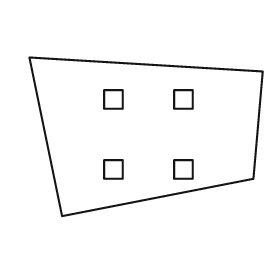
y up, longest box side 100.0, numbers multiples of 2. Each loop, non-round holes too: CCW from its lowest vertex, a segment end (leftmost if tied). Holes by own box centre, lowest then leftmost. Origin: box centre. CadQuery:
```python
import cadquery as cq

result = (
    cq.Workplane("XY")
    .moveTo(-36.0, -34.0)
    .lineTo(46.0, -18.0)
    .lineTo(50.0, 28.0)
    .lineTo(-50.0, 34.0)
    .close()
    .moveTo(-18.0, -18.0)
    .lineTo(-10.0, -18.0)
    .lineTo(-10.0, -10.0)
    .lineTo(-18.0, -10.0)
    .close()
    .moveTo(12.0, -18.0)
    .lineTo(20.0, -18.0)
    .lineTo(20.0, -10.0)
    .lineTo(12.0, -10.0)
    .close()
    .moveTo(-18.0, 12.0)
    .lineTo(-10.0, 12.0)
    .lineTo(-10.0, 20.0)
    .lineTo(-18.0, 20.0)
    .close()
    .moveTo(12.0, 12.0)
    .lineTo(20.0, 12.0)
    .lineTo(20.0, 20.0)
    .lineTo(12.0, 20.0)
    .close()
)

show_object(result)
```